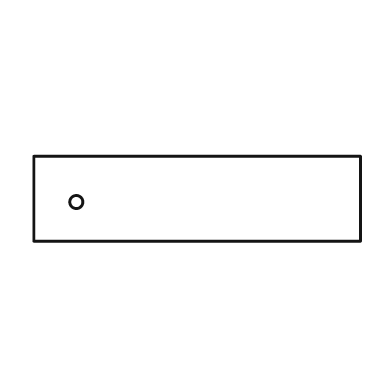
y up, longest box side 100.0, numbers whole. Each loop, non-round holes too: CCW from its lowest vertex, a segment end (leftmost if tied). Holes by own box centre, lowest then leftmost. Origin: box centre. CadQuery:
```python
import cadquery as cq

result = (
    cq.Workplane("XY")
    .moveTo(-50.0, -13.0)
    .lineTo(50.0, -13.0)
    .lineTo(50.0, 13.0)
    .lineTo(-50.0, 13.0)
    .close()
    .moveTo(-37.0, -1.0)
    .circle(2.0)
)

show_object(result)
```